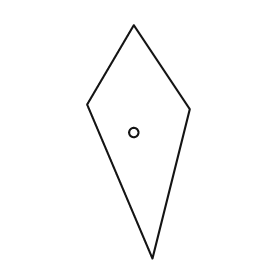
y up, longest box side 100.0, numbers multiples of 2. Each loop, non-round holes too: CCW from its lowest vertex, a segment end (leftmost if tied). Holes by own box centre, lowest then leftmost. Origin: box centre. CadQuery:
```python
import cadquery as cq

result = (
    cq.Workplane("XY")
    .moveTo(6.0, -50.0)
    .lineTo(22.0, 14.0)
    .lineTo(-2.0, 50.0)
    .lineTo(-22.0, 16.0)
    .close()
    .moveTo(-2.0, 4.0)
    .circle(2.0)
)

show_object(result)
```